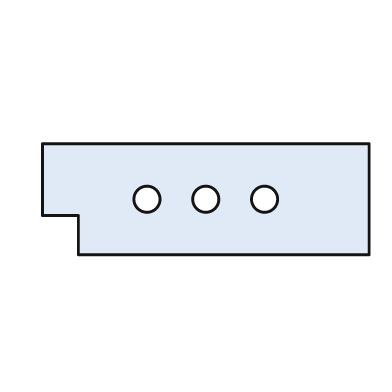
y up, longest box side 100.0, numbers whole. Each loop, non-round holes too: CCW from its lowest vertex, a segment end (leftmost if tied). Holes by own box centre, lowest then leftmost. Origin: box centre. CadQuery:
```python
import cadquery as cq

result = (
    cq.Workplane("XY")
    .moveTo(-39.0, -17.0)
    .lineTo(50.0, -17.0)
    .lineTo(50.0, 17.0)
    .lineTo(-50.0, 17.0)
    .lineTo(-50.0, -5.0)
    .lineTo(-39.0, -5.0)
    .close()
    .moveTo(-18.0, 0.0)
    .circle(4.0)
    .moveTo(0.0, 0.0)
    .circle(4.0)
    .moveTo(18.0, 0.0)
    .circle(4.0)
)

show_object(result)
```